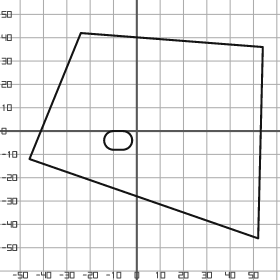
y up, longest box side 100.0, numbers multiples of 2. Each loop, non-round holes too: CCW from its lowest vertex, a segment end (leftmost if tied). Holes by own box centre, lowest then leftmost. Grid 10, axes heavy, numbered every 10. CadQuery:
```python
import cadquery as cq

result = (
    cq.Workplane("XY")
    .moveTo(52.0, -46.0)
    .lineTo(54.0, 36.0)
    .lineTo(-24.0, 42.0)
    .lineTo(-46.0, -12.0)
    .close()
    .moveTo(-10.0, -8.0)
    .lineTo(-6.0, -8.0)
    .threePointArc((-2.0, -4.0), (-6.0, 0.0))
    .lineTo(-10.0, 0.0)
    .threePointArc((-14.0, -4.0), (-10.0, -8.0))
    .close()
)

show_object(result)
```